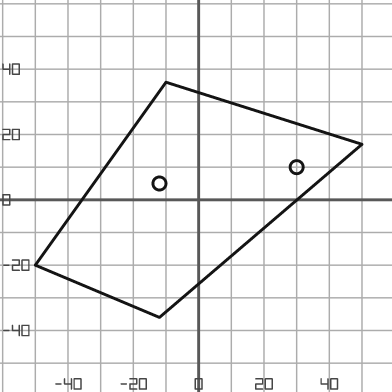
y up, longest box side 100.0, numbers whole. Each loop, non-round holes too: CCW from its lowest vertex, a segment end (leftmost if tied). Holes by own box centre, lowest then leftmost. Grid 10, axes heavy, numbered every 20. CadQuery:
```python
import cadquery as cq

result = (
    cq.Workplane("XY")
    .moveTo(-12.0, -36.0)
    .lineTo(50.0, 17.0)
    .lineTo(-10.0, 36.0)
    .lineTo(-50.0, -20.0)
    .close()
    .moveTo(-12.0, 5.0)
    .circle(2.0)
    .moveTo(30.0, 10.0)
    .circle(2.0)
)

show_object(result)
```